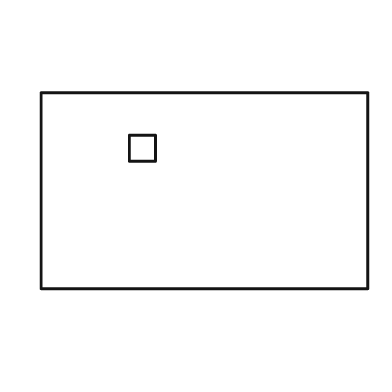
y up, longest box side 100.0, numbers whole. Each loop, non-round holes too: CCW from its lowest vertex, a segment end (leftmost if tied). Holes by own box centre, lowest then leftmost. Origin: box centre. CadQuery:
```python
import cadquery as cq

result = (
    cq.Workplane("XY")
    .moveTo(-50.0, -30.0)
    .lineTo(50.0, -30.0)
    .lineTo(50.0, 30.0)
    .lineTo(-50.0, 30.0)
    .close()
    .moveTo(-23.0, 9.0)
    .lineTo(-15.0, 9.0)
    .lineTo(-15.0, 17.0)
    .lineTo(-23.0, 17.0)
    .close()
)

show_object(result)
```